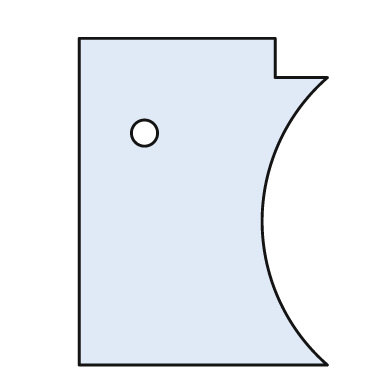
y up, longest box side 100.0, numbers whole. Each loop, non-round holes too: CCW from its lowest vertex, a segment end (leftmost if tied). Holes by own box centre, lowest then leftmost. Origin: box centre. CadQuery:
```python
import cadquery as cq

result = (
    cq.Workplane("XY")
    .moveTo(-38.0, -50.0)
    .lineTo(38.0, -50.0)
    .threePointArc((18.0, -6.0), (38.0, 38.0))
    .lineTo(22.0, 38.0)
    .lineTo(22.0, 50.0)
    .lineTo(-38.0, 50.0)
    .close()
    .moveTo(-18.0, 21.0)
    .circle(4.0)
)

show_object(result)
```